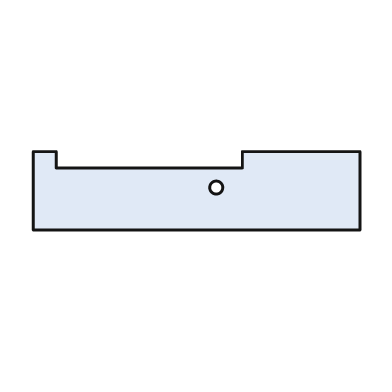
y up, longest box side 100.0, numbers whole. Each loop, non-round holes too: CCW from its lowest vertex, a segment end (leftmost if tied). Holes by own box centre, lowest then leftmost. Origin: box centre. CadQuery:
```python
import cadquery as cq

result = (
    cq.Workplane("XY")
    .moveTo(-50.0, -12.0)
    .lineTo(50.0, -12.0)
    .lineTo(50.0, 12.0)
    .lineTo(14.0, 12.0)
    .lineTo(14.0, 7.0)
    .lineTo(-43.0, 7.0)
    .lineTo(-43.0, 12.0)
    .lineTo(-50.0, 12.0)
    .close()
    .moveTo(6.0, 1.0)
    .circle(2.0)
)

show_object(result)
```